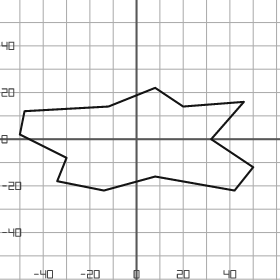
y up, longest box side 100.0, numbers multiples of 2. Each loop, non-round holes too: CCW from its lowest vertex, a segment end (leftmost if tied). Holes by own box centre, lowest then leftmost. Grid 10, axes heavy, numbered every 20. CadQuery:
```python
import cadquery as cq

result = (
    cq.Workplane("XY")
    .moveTo(-14.0, -22.0)
    .lineTo(8.0, -16.0)
    .lineTo(42.0, -22.0)
    .lineTo(50.0, -12.0)
    .lineTo(32.0, 0.0)
    .lineTo(46.0, 16.0)
    .lineTo(20.0, 14.0)
    .lineTo(8.0, 22.0)
    .lineTo(-12.0, 14.0)
    .lineTo(-48.0, 12.0)
    .lineTo(-50.0, 2.0)
    .lineTo(-30.0, -8.0)
    .lineTo(-34.0, -18.0)
    .close()
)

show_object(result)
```